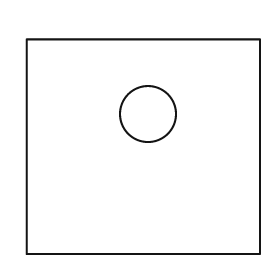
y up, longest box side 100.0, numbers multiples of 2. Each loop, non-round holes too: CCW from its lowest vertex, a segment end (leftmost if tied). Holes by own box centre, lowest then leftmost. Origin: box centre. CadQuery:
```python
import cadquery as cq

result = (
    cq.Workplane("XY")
    .moveTo(-50.0, -46.0)
    .lineTo(50.0, -46.0)
    .lineTo(50.0, 46.0)
    .lineTo(-50.0, 46.0)
    .close()
    .moveTo(2.0, 14.0)
    .circle(12.0)
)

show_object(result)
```